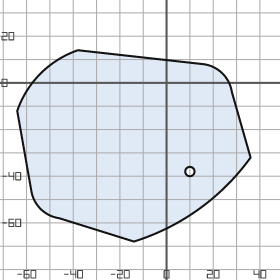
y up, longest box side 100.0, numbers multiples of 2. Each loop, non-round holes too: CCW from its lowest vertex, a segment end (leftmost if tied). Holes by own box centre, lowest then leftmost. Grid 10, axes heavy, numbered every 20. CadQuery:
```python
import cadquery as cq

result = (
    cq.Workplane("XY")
    .moveTo(-14.0, -68.0)
    .threePointArc((14.0, -54.0), (36.0, -32.0))
    .lineTo(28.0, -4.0)
    .threePointArc((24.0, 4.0), (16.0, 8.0))
    .lineTo(-38.0, 14.0)
    .threePointArc((-54.0, 4.0), (-64.0, -12.0))
    .lineTo(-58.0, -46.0)
    .threePointArc((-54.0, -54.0), (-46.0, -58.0))
    .close()
    .moveTo(10.0, -38.0)
    .circle(2.0)
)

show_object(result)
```